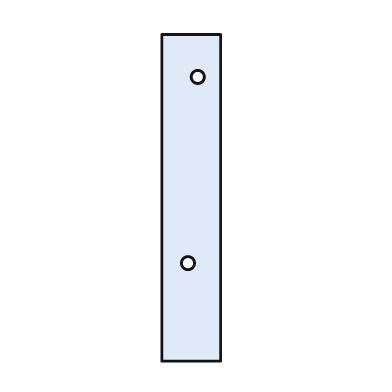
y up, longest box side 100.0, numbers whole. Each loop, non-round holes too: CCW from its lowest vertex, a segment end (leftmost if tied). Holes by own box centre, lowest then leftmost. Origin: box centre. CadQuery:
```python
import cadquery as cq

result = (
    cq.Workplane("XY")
    .moveTo(-9.0, -50.0)
    .lineTo(9.0, -50.0)
    .lineTo(9.0, 50.0)
    .lineTo(-9.0, 50.0)
    .close()
    .moveTo(-1.0, -20.0)
    .circle(2.0)
    .moveTo(2.0, 37.0)
    .circle(2.0)
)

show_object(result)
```